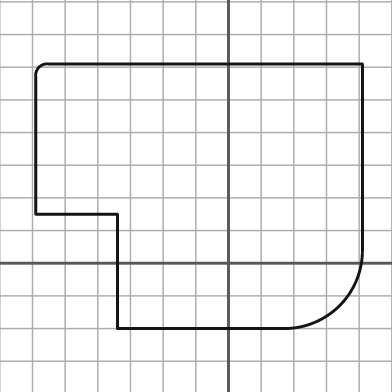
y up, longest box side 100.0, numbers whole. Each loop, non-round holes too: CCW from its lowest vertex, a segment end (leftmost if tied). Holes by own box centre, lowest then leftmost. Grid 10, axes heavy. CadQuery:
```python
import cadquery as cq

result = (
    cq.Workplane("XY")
    .moveTo(-34.0, -20.0)
    .lineTo(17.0, -20.0)
    .threePointArc((34.0, -13.0), (41.0, 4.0))
    .lineTo(41.0, 61.0)
    .lineTo(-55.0, 61.0)
    .threePointArc((-58.0, 60.0), (-59.0, 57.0))
    .lineTo(-59.0, 15.0)
    .lineTo(-34.0, 15.0)
    .close()
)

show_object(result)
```